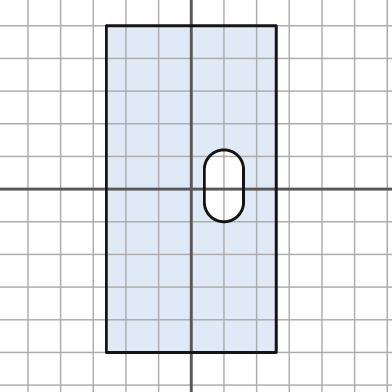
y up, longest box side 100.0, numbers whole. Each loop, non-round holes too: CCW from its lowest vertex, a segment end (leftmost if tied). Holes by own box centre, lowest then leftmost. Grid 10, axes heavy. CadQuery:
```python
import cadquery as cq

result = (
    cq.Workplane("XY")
    .moveTo(-26.0, -50.0)
    .lineTo(26.0, -50.0)
    .lineTo(26.0, 50.0)
    .lineTo(-26.0, 50.0)
    .close()
    .moveTo(4.0, -4.0)
    .threePointArc((10.0, -10.0), (16.0, -4.0))
    .lineTo(16.0, 6.0)
    .threePointArc((10.0, 12.0), (4.0, 6.0))
    .close()
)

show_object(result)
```